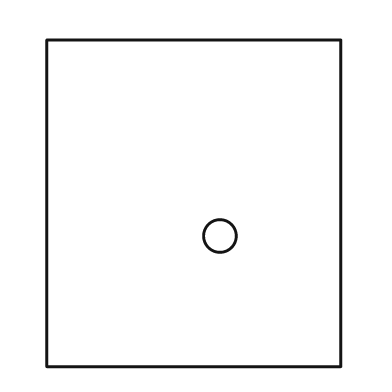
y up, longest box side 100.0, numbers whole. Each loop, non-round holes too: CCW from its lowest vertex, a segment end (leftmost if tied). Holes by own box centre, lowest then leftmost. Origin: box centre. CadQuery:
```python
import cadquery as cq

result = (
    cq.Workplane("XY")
    .moveTo(-45.0, -50.0)
    .lineTo(45.0, -50.0)
    .lineTo(45.0, 50.0)
    .lineTo(-45.0, 50.0)
    .close()
    .moveTo(8.0, -10.0)
    .circle(5.0)
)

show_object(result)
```